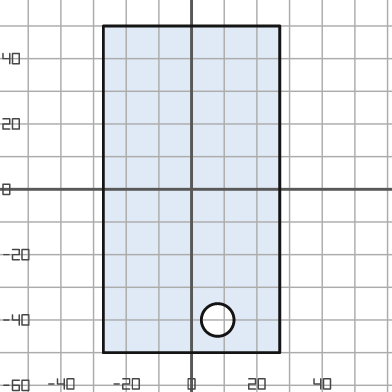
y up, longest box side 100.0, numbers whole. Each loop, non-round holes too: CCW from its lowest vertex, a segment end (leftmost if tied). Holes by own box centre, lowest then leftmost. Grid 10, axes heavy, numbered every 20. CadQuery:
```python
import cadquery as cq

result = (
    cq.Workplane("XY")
    .moveTo(-27.0, -50.0)
    .lineTo(27.0, -50.0)
    .lineTo(27.0, 50.0)
    .lineTo(-27.0, 50.0)
    .close()
    .moveTo(8.0, -40.0)
    .circle(5.0)
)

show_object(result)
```